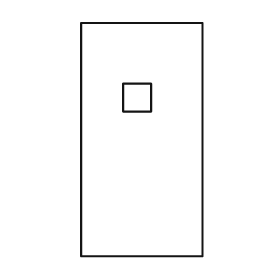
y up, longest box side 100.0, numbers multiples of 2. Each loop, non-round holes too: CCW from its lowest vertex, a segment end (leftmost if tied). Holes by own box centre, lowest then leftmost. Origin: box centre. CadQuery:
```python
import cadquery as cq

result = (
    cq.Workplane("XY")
    .moveTo(-26.0, -50.0)
    .lineTo(26.0, -50.0)
    .lineTo(26.0, 50.0)
    .lineTo(-26.0, 50.0)
    .close()
    .moveTo(-8.0, 12.0)
    .lineTo(4.0, 12.0)
    .lineTo(4.0, 24.0)
    .lineTo(-8.0, 24.0)
    .close()
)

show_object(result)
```